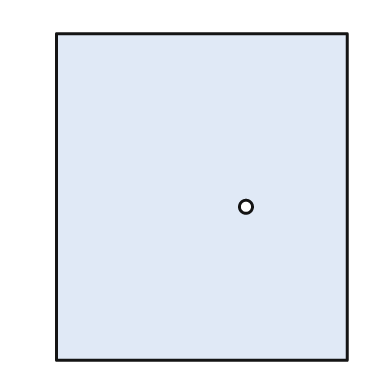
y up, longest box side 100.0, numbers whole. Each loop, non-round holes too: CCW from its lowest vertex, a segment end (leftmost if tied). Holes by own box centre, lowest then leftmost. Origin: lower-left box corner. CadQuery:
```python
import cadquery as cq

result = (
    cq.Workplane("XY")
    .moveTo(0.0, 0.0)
    .lineTo(89.0, 0.0)
    .lineTo(89.0, 100.0)
    .lineTo(0.0, 100.0)
    .close()
    .moveTo(58.0, 47.0)
    .circle(2.0)
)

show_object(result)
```